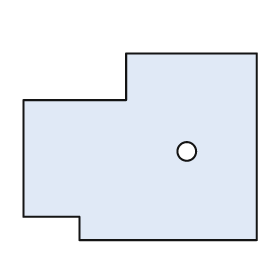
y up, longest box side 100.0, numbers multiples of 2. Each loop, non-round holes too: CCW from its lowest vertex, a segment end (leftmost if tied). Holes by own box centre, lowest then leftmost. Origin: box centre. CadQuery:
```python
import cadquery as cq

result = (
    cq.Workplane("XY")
    .moveTo(-26.0, -40.0)
    .lineTo(50.0, -40.0)
    .lineTo(50.0, 40.0)
    .lineTo(-6.0, 40.0)
    .lineTo(-6.0, 20.0)
    .lineTo(-50.0, 20.0)
    .lineTo(-50.0, -30.0)
    .lineTo(-26.0, -30.0)
    .close()
    .moveTo(20.0, -2.0)
    .circle(4.0)
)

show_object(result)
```